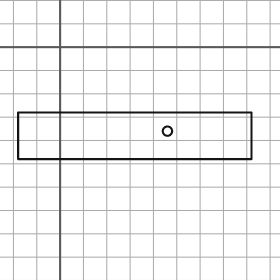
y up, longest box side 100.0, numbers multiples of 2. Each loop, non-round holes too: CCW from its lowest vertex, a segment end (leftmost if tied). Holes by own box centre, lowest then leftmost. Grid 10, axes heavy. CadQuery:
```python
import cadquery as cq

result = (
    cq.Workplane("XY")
    .moveTo(-18.0, -48.0)
    .lineTo(82.0, -48.0)
    .lineTo(82.0, -28.0)
    .lineTo(-18.0, -28.0)
    .close()
    .moveTo(46.0, -36.0)
    .circle(2.0)
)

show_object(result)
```